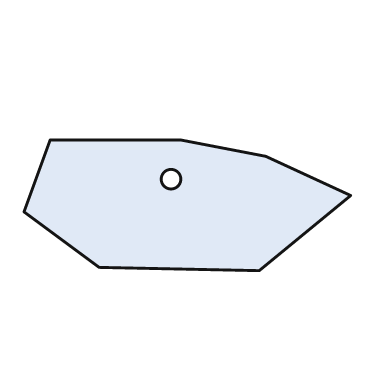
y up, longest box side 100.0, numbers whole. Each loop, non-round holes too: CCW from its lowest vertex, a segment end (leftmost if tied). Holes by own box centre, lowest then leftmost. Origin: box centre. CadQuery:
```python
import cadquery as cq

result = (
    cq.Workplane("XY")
    .moveTo(22.0, -20.0)
    .lineTo(50.0, 3.0)
    .lineTo(24.0, 15.0)
    .lineTo(-2.0, 20.0)
    .lineTo(-42.0, 20.0)
    .lineTo(-50.0, -2.0)
    .lineTo(-27.0, -19.0)
    .close()
    .moveTo(-5.0, 8.0)
    .circle(3.0)
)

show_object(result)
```